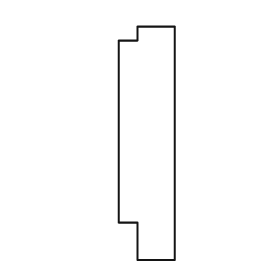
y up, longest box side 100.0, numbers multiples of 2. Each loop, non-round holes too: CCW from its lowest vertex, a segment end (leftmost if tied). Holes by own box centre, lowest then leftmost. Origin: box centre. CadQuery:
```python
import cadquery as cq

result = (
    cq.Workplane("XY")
    .moveTo(-4.0, -50.0)
    .lineTo(12.0, -50.0)
    .lineTo(12.0, 50.0)
    .lineTo(-4.0, 50.0)
    .lineTo(-4.0, 44.0)
    .lineTo(-12.0, 44.0)
    .lineTo(-12.0, -34.0)
    .lineTo(-4.0, -34.0)
    .close()
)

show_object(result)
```